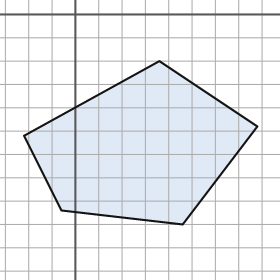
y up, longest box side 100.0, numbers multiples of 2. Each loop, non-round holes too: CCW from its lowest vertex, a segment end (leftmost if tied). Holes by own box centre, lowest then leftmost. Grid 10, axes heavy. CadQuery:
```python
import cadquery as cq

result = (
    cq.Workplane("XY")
    .moveTo(46.0, -90.0)
    .lineTo(78.0, -48.0)
    .lineTo(36.0, -20.0)
    .lineTo(-22.0, -52.0)
    .lineTo(-6.0, -84.0)
    .close()
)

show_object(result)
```